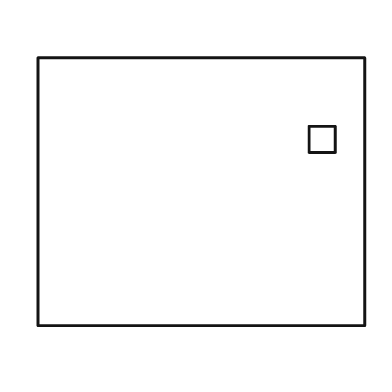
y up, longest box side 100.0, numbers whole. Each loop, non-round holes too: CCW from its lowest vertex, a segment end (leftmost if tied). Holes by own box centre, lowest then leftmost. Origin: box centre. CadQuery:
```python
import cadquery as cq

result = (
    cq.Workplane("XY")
    .moveTo(-50.0, -41.0)
    .lineTo(50.0, -41.0)
    .lineTo(50.0, 41.0)
    .lineTo(-50.0, 41.0)
    .close()
    .moveTo(33.0, 12.0)
    .lineTo(41.0, 12.0)
    .lineTo(41.0, 20.0)
    .lineTo(33.0, 20.0)
    .close()
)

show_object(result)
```